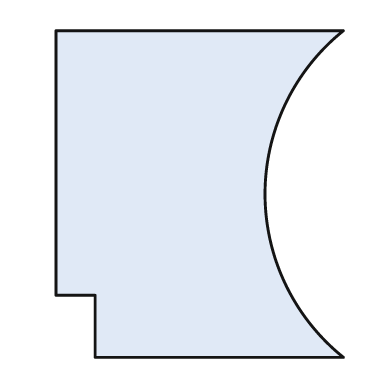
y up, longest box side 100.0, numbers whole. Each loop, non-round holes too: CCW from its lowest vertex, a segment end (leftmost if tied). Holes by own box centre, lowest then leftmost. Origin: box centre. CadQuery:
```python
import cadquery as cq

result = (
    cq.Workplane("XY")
    .moveTo(-32.0, -50.0)
    .lineTo(44.0, -50.0)
    .threePointArc((20.0, 0.0), (44.0, 50.0))
    .lineTo(-44.0, 50.0)
    .lineTo(-44.0, -31.0)
    .lineTo(-32.0, -31.0)
    .close()
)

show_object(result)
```